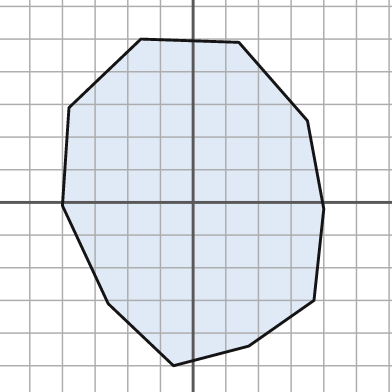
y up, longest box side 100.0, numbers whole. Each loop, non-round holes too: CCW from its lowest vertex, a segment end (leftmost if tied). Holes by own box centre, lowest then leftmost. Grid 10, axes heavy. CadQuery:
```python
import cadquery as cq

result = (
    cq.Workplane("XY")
    .moveTo(-6.0, -50.0)
    .lineTo(17.0, -44.0)
    .lineTo(37.0, -30.0)
    .lineTo(40.0, -2.0)
    .lineTo(35.0, 25.0)
    .lineTo(14.0, 49.0)
    .lineTo(-16.0, 50.0)
    .lineTo(-38.0, 29.0)
    .lineTo(-40.0, -1.0)
    .lineTo(-26.0, -31.0)
    .close()
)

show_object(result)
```